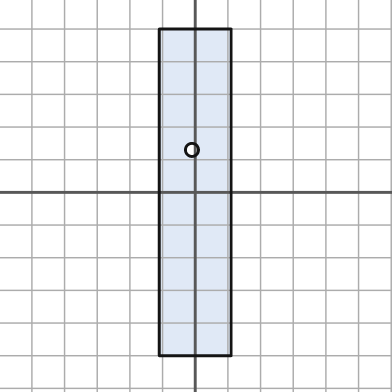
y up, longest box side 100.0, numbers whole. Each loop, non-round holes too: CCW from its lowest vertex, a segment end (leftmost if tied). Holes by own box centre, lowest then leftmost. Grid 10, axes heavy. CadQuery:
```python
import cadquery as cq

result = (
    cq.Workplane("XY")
    .moveTo(-11.0, -50.0)
    .lineTo(11.0, -50.0)
    .lineTo(11.0, 50.0)
    .lineTo(-11.0, 50.0)
    .close()
    .moveTo(-1.0, 13.0)
    .circle(2.0)
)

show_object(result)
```